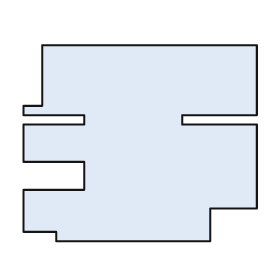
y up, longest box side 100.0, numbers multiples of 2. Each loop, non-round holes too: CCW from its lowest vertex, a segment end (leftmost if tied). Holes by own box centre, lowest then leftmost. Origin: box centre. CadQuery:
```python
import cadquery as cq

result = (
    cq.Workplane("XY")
    .moveTo(-36.0, -42.0)
    .lineTo(30.0, -42.0)
    .lineTo(30.0, -28.0)
    .lineTo(50.0, -28.0)
    .lineTo(50.0, 8.0)
    .lineTo(18.0, 8.0)
    .lineTo(18.0, 12.0)
    .lineTo(50.0, 12.0)
    .lineTo(50.0, 42.0)
    .lineTo(-42.0, 42.0)
    .lineTo(-42.0, 16.0)
    .lineTo(-50.0, 16.0)
    .lineTo(-50.0, 12.0)
    .lineTo(-24.0, 12.0)
    .lineTo(-24.0, 8.0)
    .lineTo(-50.0, 8.0)
    .lineTo(-50.0, -8.0)
    .lineTo(-24.0, -8.0)
    .lineTo(-24.0, -20.0)
    .lineTo(-50.0, -20.0)
    .lineTo(-50.0, -38.0)
    .lineTo(-36.0, -38.0)
    .close()
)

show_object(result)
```